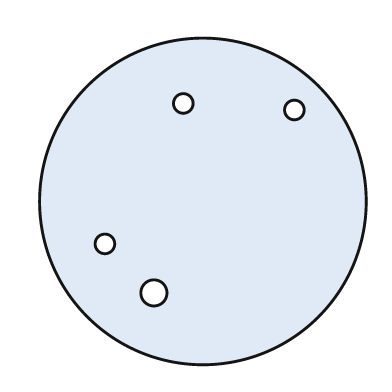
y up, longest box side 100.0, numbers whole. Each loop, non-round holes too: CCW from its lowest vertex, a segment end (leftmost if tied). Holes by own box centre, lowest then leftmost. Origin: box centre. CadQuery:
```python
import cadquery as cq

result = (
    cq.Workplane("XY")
    .moveTo(0.0, 0.0)
    .circle(50.0)
    .moveTo(-15.0, -28.0)
    .circle(4.0)
    .moveTo(-30.0, -13.0)
    .circle(3.0)
    .moveTo(28.0, 28.0)
    .circle(3.0)
    .moveTo(-6.0, 30.0)
    .circle(3.0)
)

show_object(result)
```